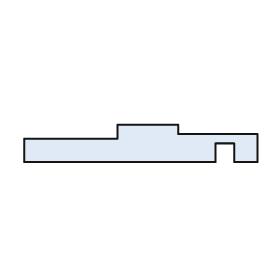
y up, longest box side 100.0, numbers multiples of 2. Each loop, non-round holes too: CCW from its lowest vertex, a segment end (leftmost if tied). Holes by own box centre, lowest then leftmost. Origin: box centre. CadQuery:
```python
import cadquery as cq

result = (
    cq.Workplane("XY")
    .moveTo(-50.0, -8.0)
    .lineTo(32.0, -8.0)
    .lineTo(32.0, 0.0)
    .lineTo(40.0, 0.0)
    .lineTo(40.0, -8.0)
    .lineTo(50.0, -8.0)
    .lineTo(50.0, 4.0)
    .lineTo(16.0, 4.0)
    .lineTo(16.0, 8.0)
    .lineTo(-10.0, 8.0)
    .lineTo(-10.0, 2.0)
    .lineTo(-50.0, 2.0)
    .close()
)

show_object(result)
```